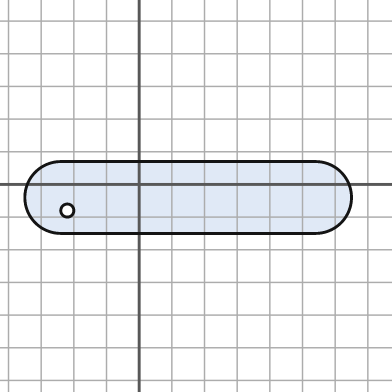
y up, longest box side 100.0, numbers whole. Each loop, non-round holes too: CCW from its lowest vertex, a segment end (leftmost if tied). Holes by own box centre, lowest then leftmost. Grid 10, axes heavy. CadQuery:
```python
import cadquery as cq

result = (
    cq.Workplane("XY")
    .moveTo(-24.0, -15.0)
    .lineTo(54.0, -15.0)
    .threePointArc((65.0, -4.0), (54.0, 7.0))
    .lineTo(-24.0, 7.0)
    .threePointArc((-35.0, -4.0), (-24.0, -15.0))
    .close()
    .moveTo(-22.0, -8.0)
    .circle(2.0)
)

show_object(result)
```